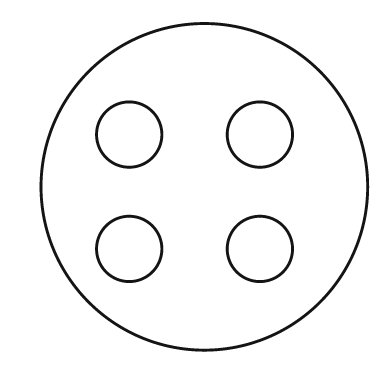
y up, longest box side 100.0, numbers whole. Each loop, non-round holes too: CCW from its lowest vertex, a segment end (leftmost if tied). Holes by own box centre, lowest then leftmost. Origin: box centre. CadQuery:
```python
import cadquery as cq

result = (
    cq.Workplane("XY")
    .moveTo(0.0, 0.0)
    .circle(50.0)
    .moveTo(-23.0, -19.0)
    .circle(10.0)
    .moveTo(17.0, -19.0)
    .circle(10.0)
    .moveTo(-23.0, 16.0)
    .circle(10.0)
    .moveTo(17.0, 16.0)
    .circle(10.0)
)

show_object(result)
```